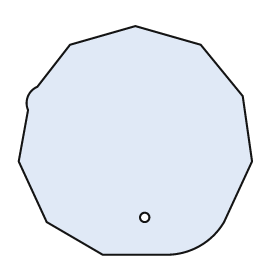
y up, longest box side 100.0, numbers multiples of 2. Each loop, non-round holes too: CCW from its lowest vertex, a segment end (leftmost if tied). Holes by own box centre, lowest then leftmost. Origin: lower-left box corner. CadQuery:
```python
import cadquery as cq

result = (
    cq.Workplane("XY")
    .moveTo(36.0, 0.0)
    .lineTo(64.0, 0.0)
    .threePointArc((78.0, 4.0), (88.0, 14.0))
    .lineTo(100.0, 40.0)
    .lineTo(96.0, 68.0)
    .lineTo(78.0, 90.0)
    .lineTo(50.0, 98.0)
    .lineTo(22.0, 90.0)
    .lineTo(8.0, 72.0)
    .threePointArc((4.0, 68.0), (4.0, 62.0))
    .lineTo(0.0, 40.0)
    .lineTo(12.0, 14.0)
    .close()
    .moveTo(54.0, 16.0)
    .circle(2.0)
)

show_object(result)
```